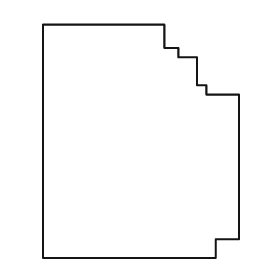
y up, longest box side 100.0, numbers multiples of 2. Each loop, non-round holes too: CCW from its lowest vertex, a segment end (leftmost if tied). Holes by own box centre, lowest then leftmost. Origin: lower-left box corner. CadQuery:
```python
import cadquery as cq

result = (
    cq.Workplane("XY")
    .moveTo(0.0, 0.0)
    .lineTo(74.0, 0.0)
    .lineTo(74.0, 8.0)
    .lineTo(84.0, 8.0)
    .lineTo(84.0, 70.0)
    .lineTo(70.0, 70.0)
    .lineTo(70.0, 74.0)
    .lineTo(66.0, 74.0)
    .lineTo(66.0, 86.0)
    .lineTo(58.0, 86.0)
    .lineTo(58.0, 90.0)
    .lineTo(52.0, 90.0)
    .lineTo(52.0, 100.0)
    .lineTo(0.0, 100.0)
    .close()
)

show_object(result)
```